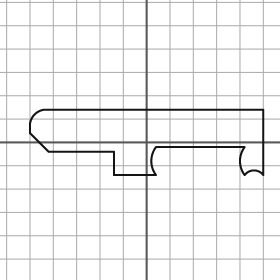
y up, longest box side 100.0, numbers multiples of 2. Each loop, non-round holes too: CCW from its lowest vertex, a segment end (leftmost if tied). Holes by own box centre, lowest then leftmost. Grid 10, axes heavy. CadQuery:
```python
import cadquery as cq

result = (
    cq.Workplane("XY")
    .moveTo(-14.0, -14.0)
    .lineTo(4.0, -14.0)
    .threePointArc((2.0, -8.0), (4.0, -2.0))
    .lineTo(42.0, -2.0)
    .threePointArc((40.0, -8.0), (42.0, -14.0))
    .threePointArc((46.0, -12.0), (50.0, -14.0))
    .lineTo(50.0, 14.0)
    .lineTo(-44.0, 14.0)
    .threePointArc((-48.0, 12.0), (-50.0, 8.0))
    .lineTo(-50.0, 4.0)
    .lineTo(-42.0, -4.0)
    .lineTo(-14.0, -4.0)
    .close()
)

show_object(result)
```